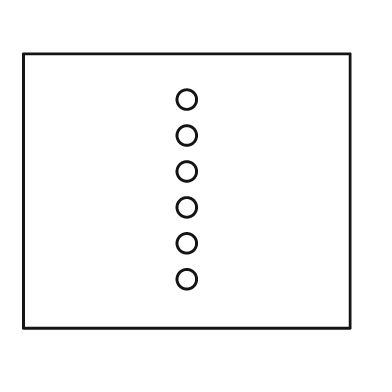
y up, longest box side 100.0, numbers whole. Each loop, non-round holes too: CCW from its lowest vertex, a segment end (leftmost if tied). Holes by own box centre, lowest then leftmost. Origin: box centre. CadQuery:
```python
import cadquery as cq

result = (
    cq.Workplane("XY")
    .moveTo(-50.0, -42.0)
    .lineTo(50.0, -42.0)
    .lineTo(50.0, 42.0)
    .lineTo(-50.0, 42.0)
    .close()
    .moveTo(0.0, -27.0)
    .circle(3.0)
    .moveTo(0.0, -16.0)
    .circle(3.0)
    .moveTo(0.0, -5.0)
    .circle(3.0)
    .moveTo(0.0, 6.0)
    .circle(3.0)
    .moveTo(0.0, 17.0)
    .circle(3.0)
    .moveTo(0.0, 28.0)
    .circle(3.0)
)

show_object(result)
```